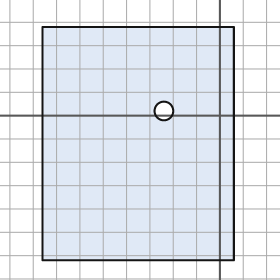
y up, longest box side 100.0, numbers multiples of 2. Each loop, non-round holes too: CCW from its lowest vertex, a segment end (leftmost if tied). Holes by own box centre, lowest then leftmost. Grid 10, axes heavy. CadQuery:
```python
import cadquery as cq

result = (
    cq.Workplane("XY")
    .moveTo(-76.0, -62.0)
    .lineTo(6.0, -62.0)
    .lineTo(6.0, 38.0)
    .lineTo(-76.0, 38.0)
    .close()
    .moveTo(-24.0, 2.0)
    .circle(4.0)
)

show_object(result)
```